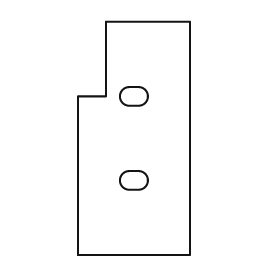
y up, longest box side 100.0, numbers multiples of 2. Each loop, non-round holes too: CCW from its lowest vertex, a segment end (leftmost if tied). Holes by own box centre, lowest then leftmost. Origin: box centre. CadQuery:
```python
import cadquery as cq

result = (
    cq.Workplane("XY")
    .moveTo(-24.0, -50.0)
    .lineTo(24.0, -50.0)
    .lineTo(24.0, 50.0)
    .lineTo(-12.0, 50.0)
    .lineTo(-12.0, 18.0)
    .lineTo(-24.0, 18.0)
    .close()
    .moveTo(-2.0, -22.0)
    .lineTo(2.0, -22.0)
    .threePointArc((6.0, -18.0), (2.0, -14.0))
    .lineTo(-2.0, -14.0)
    .threePointArc((-6.0, -18.0), (-2.0, -22.0))
    .close()
    .moveTo(-2.0, 14.0)
    .lineTo(2.0, 14.0)
    .threePointArc((6.0, 18.0), (2.0, 22.0))
    .lineTo(-2.0, 22.0)
    .threePointArc((-6.0, 18.0), (-2.0, 14.0))
    .close()
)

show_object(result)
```